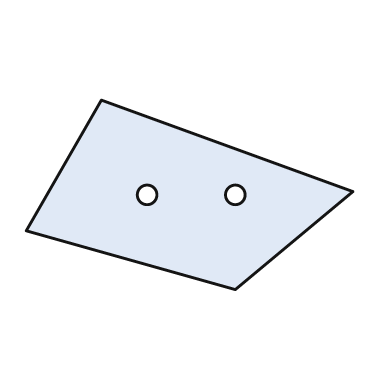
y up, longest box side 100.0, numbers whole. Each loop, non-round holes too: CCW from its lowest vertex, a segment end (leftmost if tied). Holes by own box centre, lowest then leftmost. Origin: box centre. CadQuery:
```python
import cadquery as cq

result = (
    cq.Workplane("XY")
    .moveTo(14.0, -29.0)
    .lineTo(50.0, 1.0)
    .lineTo(-27.0, 29.0)
    .lineTo(-50.0, -11.0)
    .close()
    .moveTo(-13.0, 0.0)
    .circle(3.0)
    .moveTo(14.0, 0.0)
    .circle(3.0)
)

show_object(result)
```